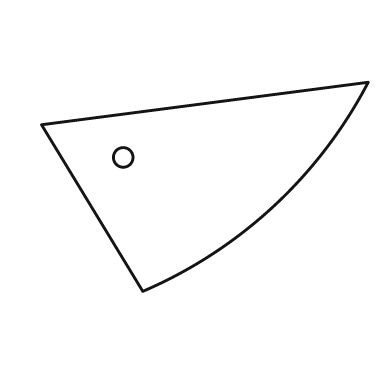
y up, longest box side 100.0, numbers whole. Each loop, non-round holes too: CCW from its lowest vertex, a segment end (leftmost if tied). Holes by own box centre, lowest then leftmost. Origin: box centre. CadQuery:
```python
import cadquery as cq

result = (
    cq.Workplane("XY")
    .moveTo(-19.0, -32.0)
    .threePointArc((21.0, -6.0), (50.0, 32.0))
    .lineTo(-50.0, 19.0)
    .close()
    .moveTo(-25.0, 9.0)
    .circle(3.0)
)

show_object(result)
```